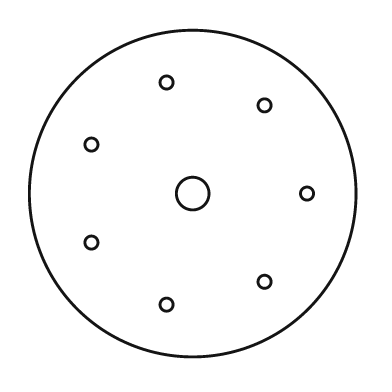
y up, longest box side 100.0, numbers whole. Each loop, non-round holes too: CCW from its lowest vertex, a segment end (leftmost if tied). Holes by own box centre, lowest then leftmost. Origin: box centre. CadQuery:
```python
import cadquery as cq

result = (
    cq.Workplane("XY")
    .moveTo(0.0, 0.0)
    .circle(50.0)
    .moveTo(-8.0, -34.0)
    .circle(2.0)
    .moveTo(22.0, -27.0)
    .circle(2.0)
    .moveTo(-31.0, -15.0)
    .circle(2.0)
    .moveTo(0.0, 0.0)
    .circle(5.0)
    .moveTo(35.0, 0.0)
    .circle(2.0)
    .moveTo(-31.0, 15.0)
    .circle(2.0)
    .moveTo(22.0, 27.0)
    .circle(2.0)
    .moveTo(-8.0, 34.0)
    .circle(2.0)
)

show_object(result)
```